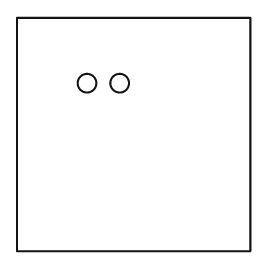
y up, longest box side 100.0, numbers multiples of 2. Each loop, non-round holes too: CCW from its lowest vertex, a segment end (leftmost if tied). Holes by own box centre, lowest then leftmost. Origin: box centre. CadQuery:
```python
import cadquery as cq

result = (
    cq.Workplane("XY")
    .moveTo(-50.0, -50.0)
    .lineTo(50.0, -50.0)
    .lineTo(50.0, 50.0)
    .lineTo(-50.0, 50.0)
    .close()
    .moveTo(-20.0, 22.0)
    .circle(4.0)
    .moveTo(-6.0, 22.0)
    .circle(4.0)
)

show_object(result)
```